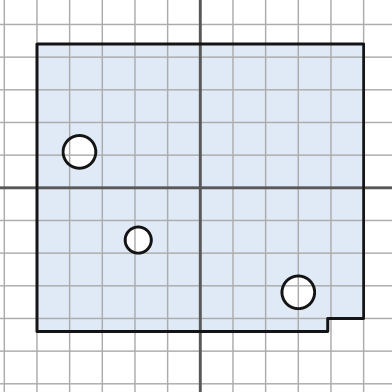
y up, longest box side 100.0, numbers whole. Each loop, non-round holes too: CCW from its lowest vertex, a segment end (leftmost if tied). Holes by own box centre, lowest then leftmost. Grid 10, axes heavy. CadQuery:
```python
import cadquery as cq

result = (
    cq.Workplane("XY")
    .moveTo(-50.0, -44.0)
    .lineTo(39.0, -44.0)
    .lineTo(39.0, -40.0)
    .lineTo(50.0, -40.0)
    .lineTo(50.0, 44.0)
    .lineTo(-50.0, 44.0)
    .close()
    .moveTo(30.0, -32.0)
    .circle(5.0)
    .moveTo(-19.0, -16.0)
    .circle(4.0)
    .moveTo(-37.0, 11.0)
    .circle(5.0)
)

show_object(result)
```